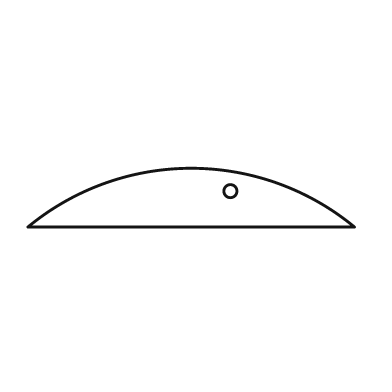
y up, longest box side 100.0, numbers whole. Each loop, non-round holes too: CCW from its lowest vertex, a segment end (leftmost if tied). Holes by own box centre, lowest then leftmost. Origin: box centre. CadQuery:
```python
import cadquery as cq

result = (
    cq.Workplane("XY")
    .moveTo(-50.0, -9.0)
    .lineTo(50.0, -9.0)
    .threePointArc((0.0, 9.0), (-50.0, -9.0))
    .close()
    .moveTo(12.0, 2.0)
    .circle(2.0)
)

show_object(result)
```